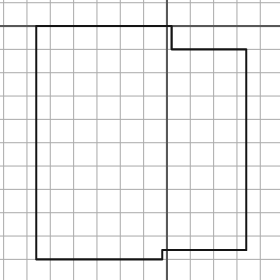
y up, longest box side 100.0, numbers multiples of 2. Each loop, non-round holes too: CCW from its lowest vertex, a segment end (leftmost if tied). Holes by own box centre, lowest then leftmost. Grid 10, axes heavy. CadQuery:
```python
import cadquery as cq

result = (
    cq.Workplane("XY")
    .moveTo(-56.0, -100.0)
    .lineTo(-2.0, -100.0)
    .lineTo(-2.0, -96.0)
    .lineTo(34.0, -96.0)
    .lineTo(34.0, -10.0)
    .lineTo(2.0, -10.0)
    .lineTo(2.0, 0.0)
    .lineTo(-56.0, 0.0)
    .close()
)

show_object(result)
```